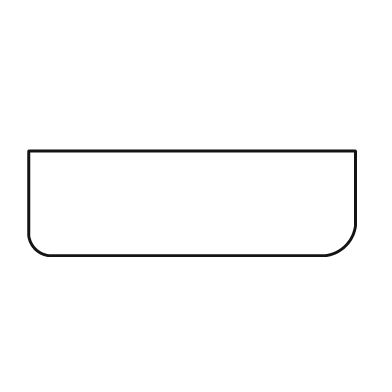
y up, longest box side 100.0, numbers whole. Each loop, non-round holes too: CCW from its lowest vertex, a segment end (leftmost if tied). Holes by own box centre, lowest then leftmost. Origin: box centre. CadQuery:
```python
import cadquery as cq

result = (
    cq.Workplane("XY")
    .moveTo(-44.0, -16.0)
    .lineTo(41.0, -16.0)
    .threePointArc((47.0, -13.0), (50.0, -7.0))
    .lineTo(50.0, 16.0)
    .lineTo(-50.0, 16.0)
    .lineTo(-50.0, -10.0)
    .threePointArc((-48.0, -14.0), (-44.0, -16.0))
    .close()
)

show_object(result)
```